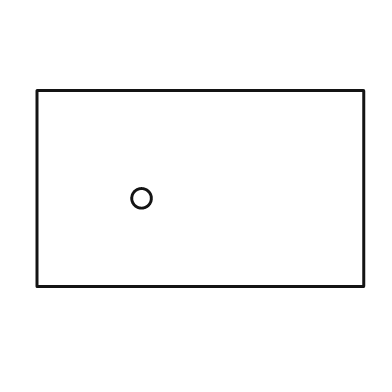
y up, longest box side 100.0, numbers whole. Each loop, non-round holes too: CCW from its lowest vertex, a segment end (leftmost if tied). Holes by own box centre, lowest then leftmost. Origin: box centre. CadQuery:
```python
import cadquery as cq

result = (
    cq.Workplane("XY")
    .moveTo(-50.0, -30.0)
    .lineTo(50.0, -30.0)
    .lineTo(50.0, 30.0)
    .lineTo(-50.0, 30.0)
    .close()
    .moveTo(-18.0, -3.0)
    .circle(3.0)
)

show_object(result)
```